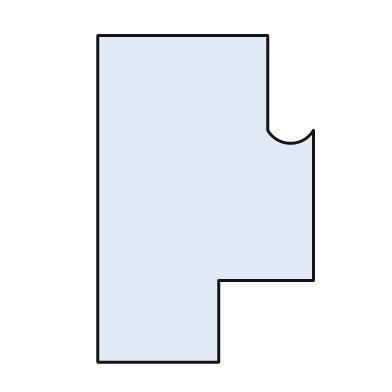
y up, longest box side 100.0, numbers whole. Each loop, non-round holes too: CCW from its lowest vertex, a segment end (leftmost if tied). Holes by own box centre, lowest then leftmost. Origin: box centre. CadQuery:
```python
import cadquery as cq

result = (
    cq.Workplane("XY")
    .moveTo(-33.0, -50.0)
    .lineTo(4.0, -50.0)
    .lineTo(4.0, -25.0)
    .lineTo(33.0, -25.0)
    .lineTo(33.0, 21.0)
    .threePointArc((26.0, 17.0), (19.0, 21.0))
    .lineTo(19.0, 50.0)
    .lineTo(-33.0, 50.0)
    .close()
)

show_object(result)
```